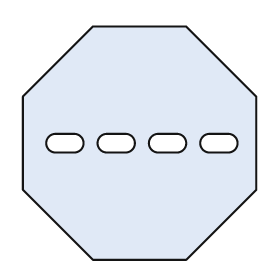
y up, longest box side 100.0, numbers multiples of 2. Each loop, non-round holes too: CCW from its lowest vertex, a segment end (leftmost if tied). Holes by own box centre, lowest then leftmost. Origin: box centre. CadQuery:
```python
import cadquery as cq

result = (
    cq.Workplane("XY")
    .moveTo(-20.0, -50.0)
    .lineTo(20.0, -50.0)
    .lineTo(50.0, -20.0)
    .lineTo(50.0, 20.0)
    .lineTo(20.0, 50.0)
    .lineTo(-20.0, 50.0)
    .lineTo(-50.0, 20.0)
    .lineTo(-50.0, -20.0)
    .close()
    .moveTo(-36.0, -4.0)
    .lineTo(-28.0, -4.0)
    .threePointArc((-24.0, 0.0), (-28.0, 4.0))
    .lineTo(-36.0, 4.0)
    .threePointArc((-40.0, 0.0), (-36.0, -4.0))
    .close()
    .moveTo(-14.0, -4.0)
    .lineTo(-6.0, -4.0)
    .threePointArc((-2.0, 0.0), (-6.0, 4.0))
    .lineTo(-14.0, 4.0)
    .threePointArc((-18.0, 0.0), (-14.0, -4.0))
    .close()
    .moveTo(8.0, -4.0)
    .lineTo(16.0, -4.0)
    .threePointArc((20.0, 0.0), (16.0, 4.0))
    .lineTo(8.0, 4.0)
    .threePointArc((4.0, 0.0), (8.0, -4.0))
    .close()
    .moveTo(30.0, -4.0)
    .lineTo(38.0, -4.0)
    .threePointArc((42.0, 0.0), (38.0, 4.0))
    .lineTo(30.0, 4.0)
    .threePointArc((26.0, 0.0), (30.0, -4.0))
    .close()
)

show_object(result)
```